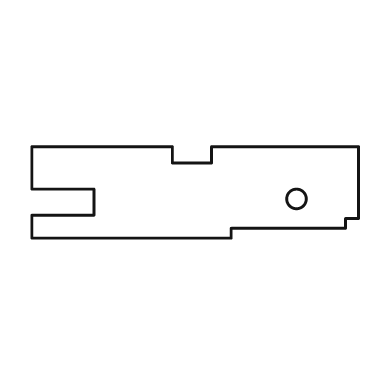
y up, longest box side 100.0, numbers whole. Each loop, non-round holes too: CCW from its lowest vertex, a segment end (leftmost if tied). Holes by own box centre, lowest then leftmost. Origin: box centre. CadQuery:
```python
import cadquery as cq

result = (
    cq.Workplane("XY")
    .moveTo(-50.0, -14.0)
    .lineTo(11.0, -14.0)
    .lineTo(11.0, -11.0)
    .lineTo(46.0, -11.0)
    .lineTo(46.0, -8.0)
    .lineTo(50.0, -8.0)
    .lineTo(50.0, 14.0)
    .lineTo(5.0, 14.0)
    .lineTo(5.0, 9.0)
    .lineTo(-7.0, 9.0)
    .lineTo(-7.0, 14.0)
    .lineTo(-50.0, 14.0)
    .lineTo(-50.0, 1.0)
    .lineTo(-31.0, 1.0)
    .lineTo(-31.0, -7.0)
    .lineTo(-50.0, -7.0)
    .close()
    .moveTo(31.0, -2.0)
    .circle(3.0)
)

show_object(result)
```